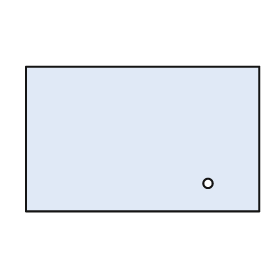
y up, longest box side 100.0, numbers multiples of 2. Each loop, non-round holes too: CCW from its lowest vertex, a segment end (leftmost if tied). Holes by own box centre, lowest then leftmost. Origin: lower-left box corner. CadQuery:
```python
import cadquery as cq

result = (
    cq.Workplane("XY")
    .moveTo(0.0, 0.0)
    .lineTo(100.0, 0.0)
    .lineTo(100.0, 62.0)
    .lineTo(0.0, 62.0)
    .close()
    .moveTo(78.0, 12.0)
    .circle(2.0)
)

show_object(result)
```